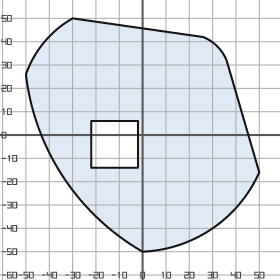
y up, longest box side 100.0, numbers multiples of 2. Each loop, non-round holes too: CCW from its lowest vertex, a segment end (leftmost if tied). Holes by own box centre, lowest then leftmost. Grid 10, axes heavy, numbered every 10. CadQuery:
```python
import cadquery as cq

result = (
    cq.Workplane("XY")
    .moveTo(0.0, -50.0)
    .threePointArc((30.0, -40.0), (50.0, -16.0))
    .lineTo(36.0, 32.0)
    .threePointArc((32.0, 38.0), (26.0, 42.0))
    .lineTo(-30.0, 50.0)
    .threePointArc((-42.0, 40.0), (-50.0, 26.0))
    .threePointArc((-34.0, -18.0), (0.0, -50.0))
    .close()
    .moveTo(-22.0, -14.0)
    .lineTo(-2.0, -14.0)
    .lineTo(-2.0, 6.0)
    .lineTo(-22.0, 6.0)
    .close()
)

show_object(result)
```